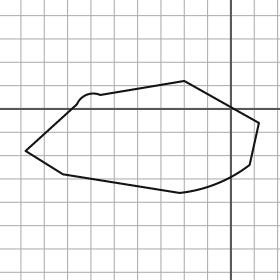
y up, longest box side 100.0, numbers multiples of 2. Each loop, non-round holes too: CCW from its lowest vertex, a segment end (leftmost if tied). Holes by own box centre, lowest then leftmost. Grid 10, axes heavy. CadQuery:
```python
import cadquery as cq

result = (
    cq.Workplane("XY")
    .moveTo(-22.0, -36.0)
    .threePointArc((-6.0, -32.0), (8.0, -24.0))
    .lineTo(12.0, -6.0)
    .lineTo(-20.0, 12.0)
    .lineTo(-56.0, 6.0)
    .threePointArc((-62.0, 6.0), (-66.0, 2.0))
    .lineTo(-88.0, -18.0)
    .lineTo(-72.0, -28.0)
    .close()
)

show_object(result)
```